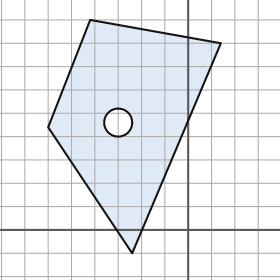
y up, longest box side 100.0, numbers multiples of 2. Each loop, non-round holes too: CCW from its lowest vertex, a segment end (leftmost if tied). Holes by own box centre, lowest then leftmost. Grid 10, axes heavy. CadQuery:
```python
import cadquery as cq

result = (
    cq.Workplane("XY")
    .moveTo(-24.0, -10.0)
    .lineTo(14.0, 80.0)
    .lineTo(-42.0, 90.0)
    .lineTo(-60.0, 44.0)
    .close()
    .moveTo(-30.0, 46.0)
    .circle(6.0)
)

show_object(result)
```